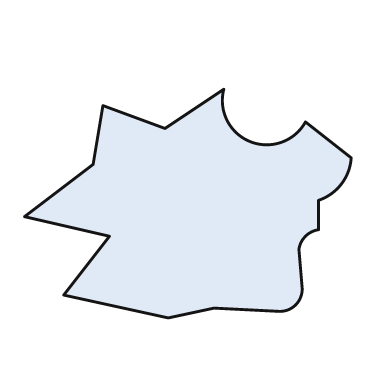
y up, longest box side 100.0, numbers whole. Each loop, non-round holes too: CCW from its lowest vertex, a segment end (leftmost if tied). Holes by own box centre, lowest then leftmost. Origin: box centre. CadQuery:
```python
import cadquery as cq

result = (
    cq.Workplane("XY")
    .moveTo(-6.0, -35.0)
    .lineTo(8.0, -32.0)
    .lineTo(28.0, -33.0)
    .threePointArc((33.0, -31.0), (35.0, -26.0))
    .lineTo(34.0, -14.0)
    .threePointArc((36.0, -10.0), (40.0, -8.0))
    .lineTo(40.0, 1.0)
    .threePointArc((47.0, 6.0), (50.0, 14.0))
    .lineTo(36.0, 25.0)
    .threePointArc((19.0, 19.0), (11.0, 35.0))
    .lineTo(-7.0, 23.0)
    .lineTo(-26.0, 30.0)
    .lineTo(-29.0, 12.0)
    .lineTo(-50.0, -4.0)
    .lineTo(-24.0, -10.0)
    .lineTo(-38.0, -28.0)
    .close()
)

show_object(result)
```